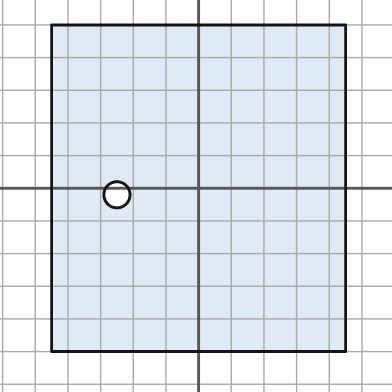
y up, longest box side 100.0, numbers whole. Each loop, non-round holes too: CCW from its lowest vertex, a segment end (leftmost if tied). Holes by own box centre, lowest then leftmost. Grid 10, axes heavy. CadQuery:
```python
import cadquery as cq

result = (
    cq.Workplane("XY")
    .moveTo(-45.0, -50.0)
    .lineTo(45.0, -50.0)
    .lineTo(45.0, 50.0)
    .lineTo(-45.0, 50.0)
    .close()
    .moveTo(-25.0, -2.0)
    .circle(4.0)
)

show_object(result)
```